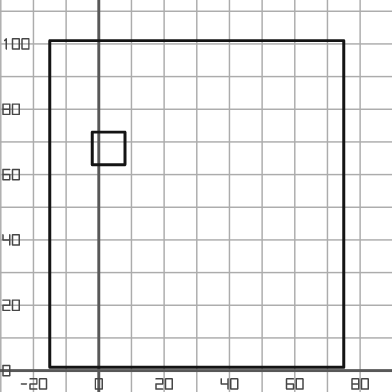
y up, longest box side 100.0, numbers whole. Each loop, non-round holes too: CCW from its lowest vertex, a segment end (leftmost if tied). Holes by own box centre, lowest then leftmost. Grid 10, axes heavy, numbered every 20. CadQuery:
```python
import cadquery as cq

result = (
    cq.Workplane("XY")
    .moveTo(-15.0, 1.0)
    .lineTo(75.0, 1.0)
    .lineTo(75.0, 101.0)
    .lineTo(-15.0, 101.0)
    .close()
    .moveTo(-2.0, 63.0)
    .lineTo(8.0, 63.0)
    .lineTo(8.0, 73.0)
    .lineTo(-2.0, 73.0)
    .close()
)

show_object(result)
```